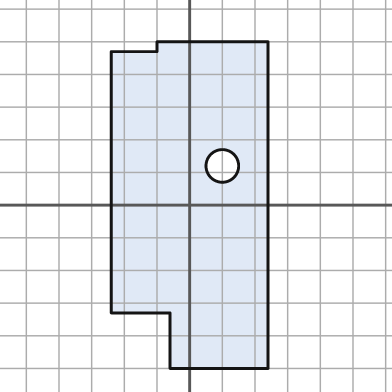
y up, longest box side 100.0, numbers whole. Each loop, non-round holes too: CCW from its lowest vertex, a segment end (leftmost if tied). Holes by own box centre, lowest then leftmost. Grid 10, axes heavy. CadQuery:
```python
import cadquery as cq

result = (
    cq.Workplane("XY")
    .moveTo(-6.0, -50.0)
    .lineTo(24.0, -50.0)
    .lineTo(24.0, 50.0)
    .lineTo(-10.0, 50.0)
    .lineTo(-10.0, 47.0)
    .lineTo(-24.0, 47.0)
    .lineTo(-24.0, -33.0)
    .lineTo(-6.0, -33.0)
    .close()
    .moveTo(10.0, 12.0)
    .circle(5.0)
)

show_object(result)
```